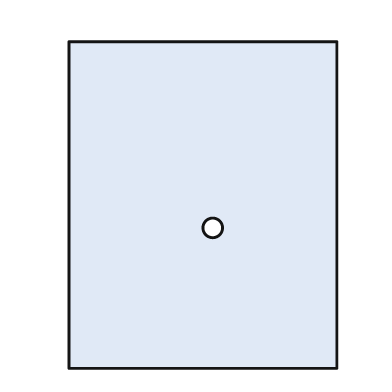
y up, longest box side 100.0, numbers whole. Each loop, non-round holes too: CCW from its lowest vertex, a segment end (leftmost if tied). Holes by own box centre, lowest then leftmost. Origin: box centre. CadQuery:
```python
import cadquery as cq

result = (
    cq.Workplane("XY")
    .moveTo(-41.0, -50.0)
    .lineTo(41.0, -50.0)
    .lineTo(41.0, 50.0)
    .lineTo(-41.0, 50.0)
    .close()
    .moveTo(3.0, -7.0)
    .circle(3.0)
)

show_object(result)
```